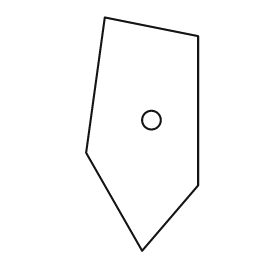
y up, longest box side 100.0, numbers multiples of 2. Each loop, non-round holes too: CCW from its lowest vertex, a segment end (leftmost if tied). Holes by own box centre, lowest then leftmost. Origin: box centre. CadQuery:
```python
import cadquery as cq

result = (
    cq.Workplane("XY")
    .moveTo(0.0, -50.0)
    .lineTo(24.0, -22.0)
    .lineTo(24.0, 42.0)
    .lineTo(-16.0, 50.0)
    .lineTo(-24.0, -8.0)
    .close()
    .moveTo(4.0, 6.0)
    .circle(4.0)
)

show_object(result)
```